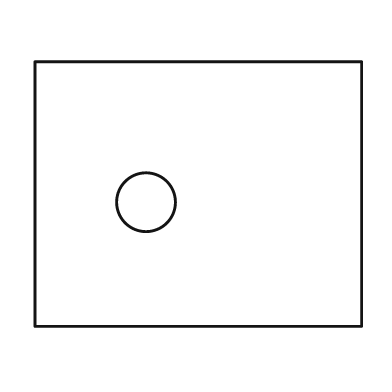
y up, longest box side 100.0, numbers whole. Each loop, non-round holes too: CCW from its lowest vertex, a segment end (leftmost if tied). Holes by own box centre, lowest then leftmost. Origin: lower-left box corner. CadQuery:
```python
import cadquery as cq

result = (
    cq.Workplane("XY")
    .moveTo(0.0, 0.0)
    .lineTo(100.0, 0.0)
    .lineTo(100.0, 81.0)
    .lineTo(0.0, 81.0)
    .close()
    .moveTo(34.0, 38.0)
    .circle(9.0)
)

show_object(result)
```